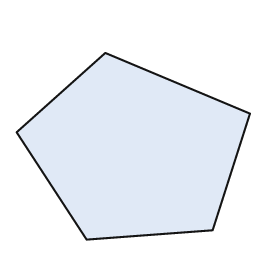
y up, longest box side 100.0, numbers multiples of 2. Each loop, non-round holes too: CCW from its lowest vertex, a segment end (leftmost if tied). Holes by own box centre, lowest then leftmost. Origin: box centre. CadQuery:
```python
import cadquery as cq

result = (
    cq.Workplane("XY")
    .moveTo(-20.0, -40.0)
    .lineTo(34.0, -36.0)
    .lineTo(50.0, 14.0)
    .lineTo(-12.0, 40.0)
    .lineTo(-50.0, 6.0)
    .close()
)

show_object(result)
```